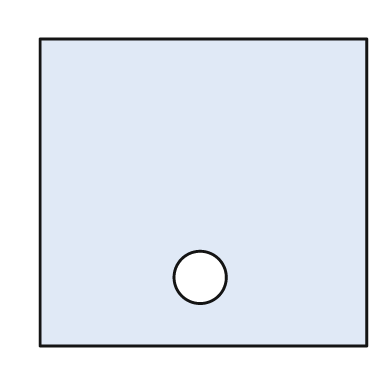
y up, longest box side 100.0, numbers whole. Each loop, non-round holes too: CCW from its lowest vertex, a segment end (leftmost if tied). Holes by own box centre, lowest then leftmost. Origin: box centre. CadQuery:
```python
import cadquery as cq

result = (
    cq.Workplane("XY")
    .moveTo(-50.0, -47.0)
    .lineTo(50.0, -47.0)
    .lineTo(50.0, 47.0)
    .lineTo(-50.0, 47.0)
    .close()
    .moveTo(-1.0, -26.0)
    .circle(8.0)
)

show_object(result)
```